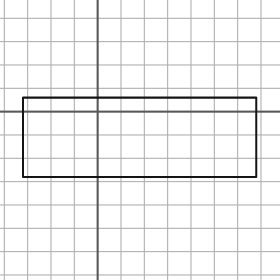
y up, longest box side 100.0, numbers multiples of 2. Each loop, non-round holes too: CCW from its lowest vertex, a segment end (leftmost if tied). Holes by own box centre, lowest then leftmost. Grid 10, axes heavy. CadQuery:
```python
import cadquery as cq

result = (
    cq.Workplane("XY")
    .moveTo(-32.0, -28.0)
    .lineTo(68.0, -28.0)
    .lineTo(68.0, 6.0)
    .lineTo(-32.0, 6.0)
    .close()
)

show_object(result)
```